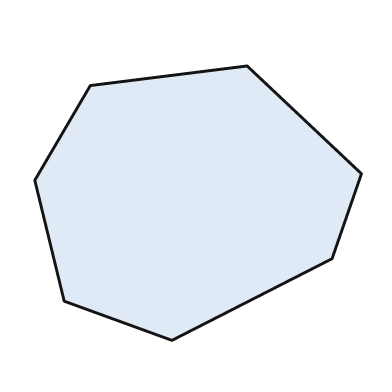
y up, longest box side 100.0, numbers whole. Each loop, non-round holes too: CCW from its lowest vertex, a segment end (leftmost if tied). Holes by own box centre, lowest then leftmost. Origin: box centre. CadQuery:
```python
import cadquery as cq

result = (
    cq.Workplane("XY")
    .moveTo(-8.0, -42.0)
    .lineTo(41.0, -17.0)
    .lineTo(50.0, 9.0)
    .lineTo(15.0, 42.0)
    .lineTo(-33.0, 36.0)
    .lineTo(-50.0, 7.0)
    .lineTo(-41.0, -30.0)
    .close()
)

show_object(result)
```